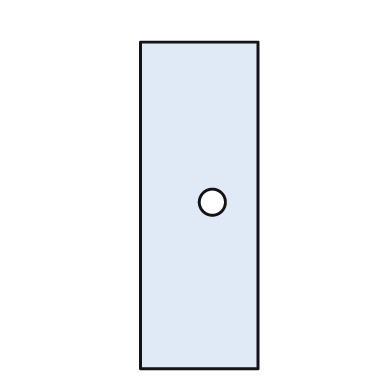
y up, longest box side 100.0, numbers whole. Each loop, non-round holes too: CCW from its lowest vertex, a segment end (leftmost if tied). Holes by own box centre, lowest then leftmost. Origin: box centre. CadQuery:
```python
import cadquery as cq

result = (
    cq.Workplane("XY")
    .moveTo(-18.0, -50.0)
    .lineTo(18.0, -50.0)
    .lineTo(18.0, 50.0)
    .lineTo(-18.0, 50.0)
    .close()
    .moveTo(4.0, 1.0)
    .circle(4.0)
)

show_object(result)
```